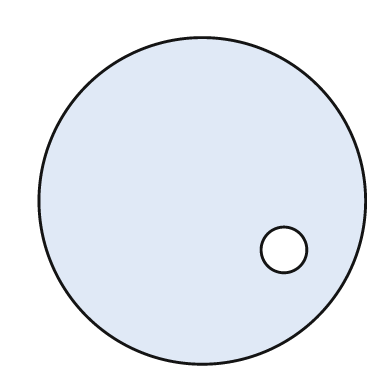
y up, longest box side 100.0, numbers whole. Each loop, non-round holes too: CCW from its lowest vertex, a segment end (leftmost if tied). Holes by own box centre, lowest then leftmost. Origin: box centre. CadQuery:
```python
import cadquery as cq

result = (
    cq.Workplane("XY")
    .moveTo(0.0, 0.0)
    .circle(50.0)
    .moveTo(25.0, -15.0)
    .circle(7.0)
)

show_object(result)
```